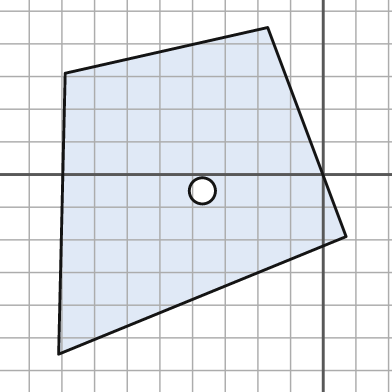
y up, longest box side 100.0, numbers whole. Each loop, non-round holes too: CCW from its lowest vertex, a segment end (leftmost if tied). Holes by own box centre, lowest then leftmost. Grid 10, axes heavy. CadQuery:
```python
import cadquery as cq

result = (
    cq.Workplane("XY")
    .moveTo(-81.0, -55.0)
    .lineTo(7.0, -19.0)
    .lineTo(-17.0, 45.0)
    .lineTo(-79.0, 31.0)
    .close()
    .moveTo(-37.0, -5.0)
    .circle(4.0)
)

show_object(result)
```